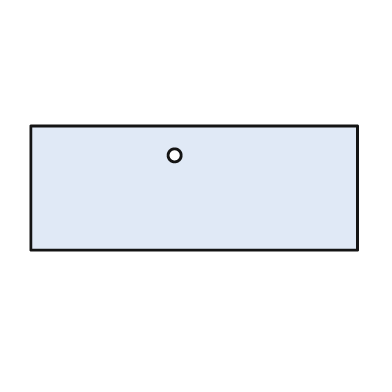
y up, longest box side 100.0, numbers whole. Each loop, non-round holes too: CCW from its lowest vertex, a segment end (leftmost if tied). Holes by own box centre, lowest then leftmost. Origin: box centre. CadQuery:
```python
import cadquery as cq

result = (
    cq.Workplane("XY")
    .moveTo(-50.0, -19.0)
    .lineTo(50.0, -19.0)
    .lineTo(50.0, 19.0)
    .lineTo(-50.0, 19.0)
    .close()
    .moveTo(-6.0, 10.0)
    .circle(2.0)
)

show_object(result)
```